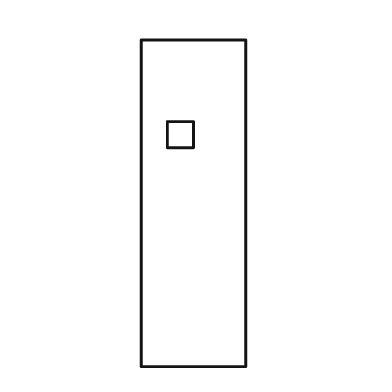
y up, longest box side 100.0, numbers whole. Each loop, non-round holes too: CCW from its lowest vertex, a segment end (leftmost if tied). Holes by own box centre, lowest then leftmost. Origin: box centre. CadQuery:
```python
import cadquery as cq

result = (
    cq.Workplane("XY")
    .moveTo(-16.0, -50.0)
    .lineTo(16.0, -50.0)
    .lineTo(16.0, 50.0)
    .lineTo(-16.0, 50.0)
    .close()
    .moveTo(-8.0, 17.0)
    .lineTo(0.0, 17.0)
    .lineTo(0.0, 25.0)
    .lineTo(-8.0, 25.0)
    .close()
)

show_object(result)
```